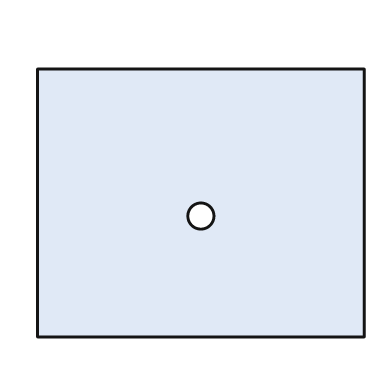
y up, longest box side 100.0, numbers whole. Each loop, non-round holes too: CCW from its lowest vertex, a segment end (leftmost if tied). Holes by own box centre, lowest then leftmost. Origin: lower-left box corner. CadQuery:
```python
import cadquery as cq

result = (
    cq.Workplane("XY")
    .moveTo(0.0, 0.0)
    .lineTo(100.0, 0.0)
    .lineTo(100.0, 82.0)
    .lineTo(0.0, 82.0)
    .close()
    .moveTo(50.0, 37.0)
    .circle(4.0)
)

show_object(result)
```